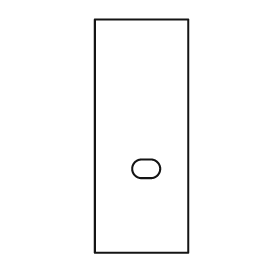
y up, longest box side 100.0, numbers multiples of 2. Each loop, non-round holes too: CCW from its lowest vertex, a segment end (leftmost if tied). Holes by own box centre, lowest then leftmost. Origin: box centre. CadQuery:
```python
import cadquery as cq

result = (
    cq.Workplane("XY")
    .moveTo(-20.0, -50.0)
    .lineTo(20.0, -50.0)
    .lineTo(20.0, 50.0)
    .lineTo(-20.0, 50.0)
    .close()
    .moveTo(0.0, -18.0)
    .lineTo(4.0, -18.0)
    .threePointArc((8.0, -14.0), (4.0, -10.0))
    .lineTo(0.0, -10.0)
    .threePointArc((-4.0, -14.0), (0.0, -18.0))
    .close()
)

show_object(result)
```